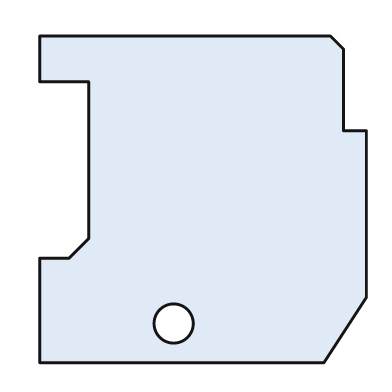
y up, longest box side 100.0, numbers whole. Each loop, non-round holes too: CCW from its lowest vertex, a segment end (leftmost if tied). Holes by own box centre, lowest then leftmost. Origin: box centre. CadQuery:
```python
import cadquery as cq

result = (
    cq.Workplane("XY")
    .moveTo(-50.0, -50.0)
    .lineTo(37.0, -50.0)
    .lineTo(50.0, -30.0)
    .lineTo(50.0, 21.0)
    .lineTo(43.0, 21.0)
    .lineTo(43.0, 46.0)
    .lineTo(39.0, 50.0)
    .lineTo(-50.0, 50.0)
    .lineTo(-50.0, 36.0)
    .lineTo(-35.0, 36.0)
    .lineTo(-35.0, -12.0)
    .lineTo(-41.0, -18.0)
    .lineTo(-50.0, -18.0)
    .close()
    .moveTo(-9.0, -38.0)
    .circle(6.0)
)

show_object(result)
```